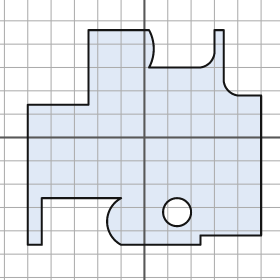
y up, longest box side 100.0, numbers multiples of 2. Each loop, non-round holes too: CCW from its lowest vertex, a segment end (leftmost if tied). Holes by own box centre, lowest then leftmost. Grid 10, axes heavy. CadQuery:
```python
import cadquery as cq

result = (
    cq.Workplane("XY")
    .moveTo(-50.0, -46.0)
    .lineTo(-44.0, -46.0)
    .lineTo(-44.0, -26.0)
    .lineTo(-10.0, -26.0)
    .threePointArc((-16.0, -36.0), (-10.0, -46.0))
    .lineTo(24.0, -46.0)
    .lineTo(24.0, -42.0)
    .lineTo(50.0, -42.0)
    .lineTo(50.0, 18.0)
    .lineTo(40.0, 18.0)
    .threePointArc((36.0, 20.0), (34.0, 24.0))
    .lineTo(34.0, 46.0)
    .lineTo(30.0, 46.0)
    .lineTo(30.0, 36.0)
    .threePointArc((28.0, 32.0), (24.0, 30.0))
    .lineTo(2.0, 30.0)
    .threePointArc((4.0, 38.0), (2.0, 46.0))
    .lineTo(-24.0, 46.0)
    .lineTo(-24.0, 14.0)
    .lineTo(-50.0, 14.0)
    .close()
    .moveTo(14.0, -32.0)
    .circle(6.0)
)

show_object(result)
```